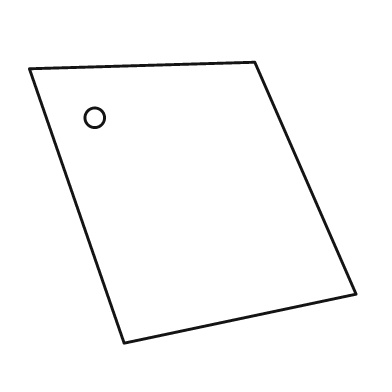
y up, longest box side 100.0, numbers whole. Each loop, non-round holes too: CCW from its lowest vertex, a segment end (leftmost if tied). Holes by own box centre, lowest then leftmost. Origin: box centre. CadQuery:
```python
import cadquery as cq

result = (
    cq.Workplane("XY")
    .moveTo(-21.0, -43.0)
    .lineTo(50.0, -28.0)
    .lineTo(19.0, 43.0)
    .lineTo(-50.0, 41.0)
    .close()
    .moveTo(-30.0, 26.0)
    .circle(3.0)
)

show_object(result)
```